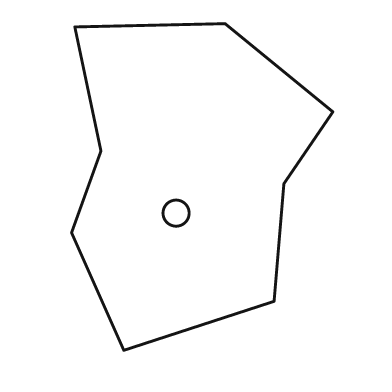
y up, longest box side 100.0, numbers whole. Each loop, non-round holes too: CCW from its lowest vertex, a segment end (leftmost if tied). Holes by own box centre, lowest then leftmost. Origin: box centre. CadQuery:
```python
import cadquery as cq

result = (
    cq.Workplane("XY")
    .moveTo(-24.0, -50.0)
    .lineTo(22.0, -35.0)
    .lineTo(25.0, 1.0)
    .lineTo(40.0, 23.0)
    .lineTo(7.0, 50.0)
    .lineTo(-39.0, 49.0)
    .lineTo(-31.0, 11.0)
    .lineTo(-40.0, -14.0)
    .close()
    .moveTo(-8.0, -8.0)
    .circle(4.0)
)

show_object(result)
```